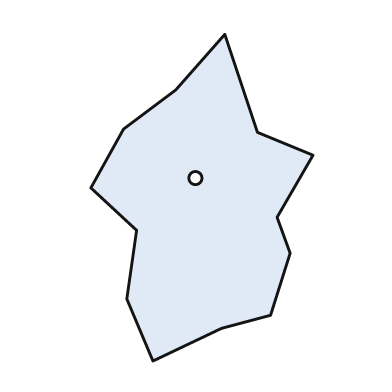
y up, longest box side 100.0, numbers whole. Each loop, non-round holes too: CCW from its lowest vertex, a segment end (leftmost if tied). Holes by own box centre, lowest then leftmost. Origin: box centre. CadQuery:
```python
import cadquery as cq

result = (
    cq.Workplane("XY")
    .moveTo(-15.0, -50.0)
    .lineTo(6.0, -40.0)
    .lineTo(21.0, -36.0)
    .lineTo(27.0, -17.0)
    .lineTo(23.0, -6.0)
    .lineTo(34.0, 13.0)
    .lineTo(17.0, 20.0)
    .lineTo(7.0, 50.0)
    .lineTo(-8.0, 33.0)
    .lineTo(-24.0, 21.0)
    .lineTo(-34.0, 3.0)
    .lineTo(-20.0, -10.0)
    .lineTo(-23.0, -31.0)
    .close()
    .moveTo(-2.0, 6.0)
    .circle(2.0)
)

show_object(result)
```